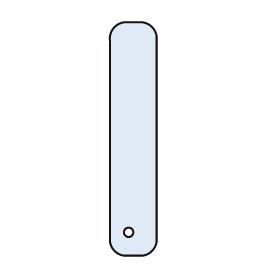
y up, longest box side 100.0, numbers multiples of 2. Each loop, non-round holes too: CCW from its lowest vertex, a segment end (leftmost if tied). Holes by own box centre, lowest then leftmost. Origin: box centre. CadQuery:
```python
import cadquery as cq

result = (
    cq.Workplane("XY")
    .moveTo(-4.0, -50.0)
    .lineTo(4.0, -50.0)
    .threePointArc((8.0, -48.0), (10.0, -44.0))
    .lineTo(10.0, 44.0)
    .threePointArc((8.0, 48.0), (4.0, 50.0))
    .lineTo(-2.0, 50.0)
    .threePointArc((-8.0, 48.0), (-10.0, 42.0))
    .lineTo(-10.0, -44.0)
    .threePointArc((-8.0, -48.0), (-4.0, -50.0))
    .close()
    .moveTo(-2.0, -40.0)
    .circle(2.0)
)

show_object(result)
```